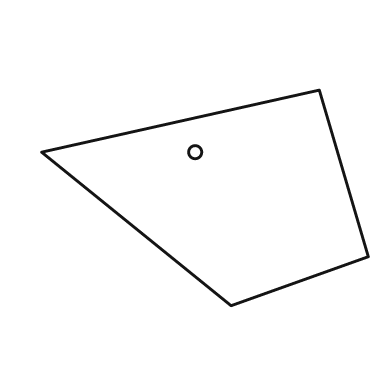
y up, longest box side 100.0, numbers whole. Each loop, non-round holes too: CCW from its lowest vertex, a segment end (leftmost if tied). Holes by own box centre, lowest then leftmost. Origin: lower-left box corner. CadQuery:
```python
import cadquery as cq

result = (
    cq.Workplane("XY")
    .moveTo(58.0, 0.0)
    .lineTo(100.0, 15.0)
    .lineTo(85.0, 66.0)
    .lineTo(0.0, 47.0)
    .close()
    .moveTo(47.0, 47.0)
    .circle(2.0)
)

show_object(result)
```